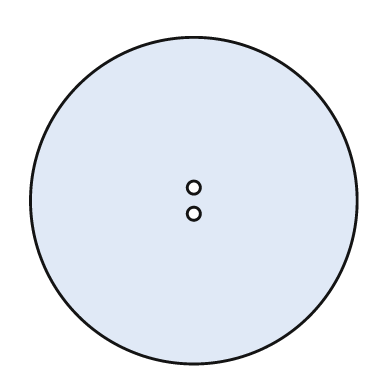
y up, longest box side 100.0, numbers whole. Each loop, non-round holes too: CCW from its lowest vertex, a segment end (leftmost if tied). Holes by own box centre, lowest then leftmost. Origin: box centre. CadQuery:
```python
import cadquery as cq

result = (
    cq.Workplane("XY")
    .moveTo(0.0, 0.0)
    .circle(50.0)
    .moveTo(0.0, -4.0)
    .circle(2.0)
    .moveTo(0.0, 4.0)
    .circle(2.0)
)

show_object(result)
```